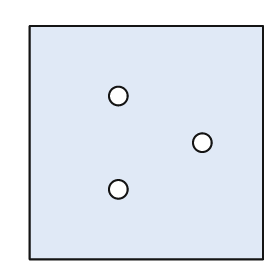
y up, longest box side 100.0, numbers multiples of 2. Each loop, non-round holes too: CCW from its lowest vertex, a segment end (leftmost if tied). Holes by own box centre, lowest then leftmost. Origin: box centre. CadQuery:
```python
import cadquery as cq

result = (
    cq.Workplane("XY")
    .moveTo(-50.0, -50.0)
    .lineTo(50.0, -50.0)
    .lineTo(50.0, 50.0)
    .lineTo(-50.0, 50.0)
    .close()
    .moveTo(-12.0, -20.0)
    .circle(4.0)
    .moveTo(24.0, 0.0)
    .circle(4.0)
    .moveTo(-12.0, 20.0)
    .circle(4.0)
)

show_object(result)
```